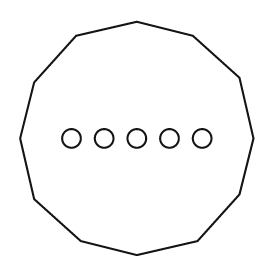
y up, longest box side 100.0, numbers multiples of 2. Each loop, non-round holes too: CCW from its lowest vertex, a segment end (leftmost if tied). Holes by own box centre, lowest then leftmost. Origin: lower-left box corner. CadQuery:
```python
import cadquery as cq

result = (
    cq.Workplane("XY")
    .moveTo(50.0, 0.0)
    .lineTo(76.0, 6.0)
    .lineTo(94.0, 26.0)
    .lineTo(100.0, 50.0)
    .lineTo(94.0, 76.0)
    .lineTo(74.0, 94.0)
    .lineTo(50.0, 100.0)
    .lineTo(24.0, 94.0)
    .lineTo(6.0, 74.0)
    .lineTo(0.0, 50.0)
    .lineTo(6.0, 24.0)
    .lineTo(26.0, 6.0)
    .close()
    .moveTo(22.0, 50.0)
    .circle(4.0)
    .moveTo(36.0, 50.0)
    .circle(4.0)
    .moveTo(50.0, 50.0)
    .circle(4.0)
    .moveTo(64.0, 50.0)
    .circle(4.0)
    .moveTo(78.0, 50.0)
    .circle(4.0)
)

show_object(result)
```